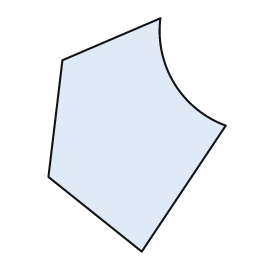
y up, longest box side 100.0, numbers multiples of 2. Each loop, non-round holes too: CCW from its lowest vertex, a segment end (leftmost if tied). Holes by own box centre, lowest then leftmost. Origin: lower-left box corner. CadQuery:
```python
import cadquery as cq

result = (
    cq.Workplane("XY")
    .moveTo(40.0, 0.0)
    .lineTo(76.0, 54.0)
    .threePointArc((54.0, 72.0), (48.0, 100.0))
    .lineTo(6.0, 82.0)
    .lineTo(0.0, 32.0)
    .close()
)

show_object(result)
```